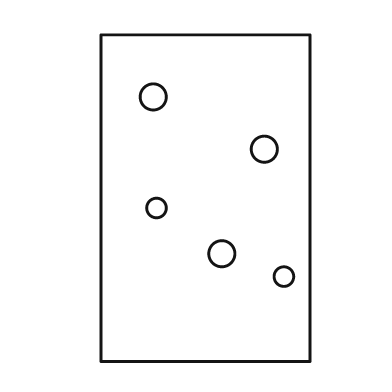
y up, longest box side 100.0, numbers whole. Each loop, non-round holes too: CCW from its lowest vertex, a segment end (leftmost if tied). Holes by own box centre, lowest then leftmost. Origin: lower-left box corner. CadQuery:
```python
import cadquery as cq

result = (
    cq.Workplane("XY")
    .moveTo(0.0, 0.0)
    .lineTo(64.0, 0.0)
    .lineTo(64.0, 100.0)
    .lineTo(0.0, 100.0)
    .close()
    .moveTo(56.0, 26.0)
    .circle(3.0)
    .moveTo(37.0, 33.0)
    .circle(4.0)
    .moveTo(17.0, 47.0)
    .circle(3.0)
    .moveTo(50.0, 65.0)
    .circle(4.0)
    .moveTo(16.0, 81.0)
    .circle(4.0)
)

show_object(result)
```